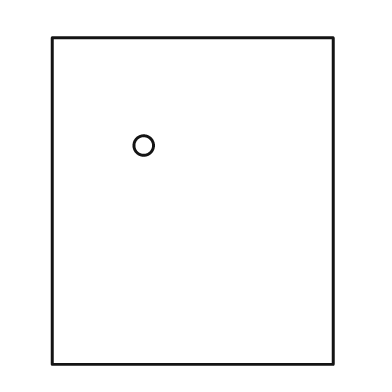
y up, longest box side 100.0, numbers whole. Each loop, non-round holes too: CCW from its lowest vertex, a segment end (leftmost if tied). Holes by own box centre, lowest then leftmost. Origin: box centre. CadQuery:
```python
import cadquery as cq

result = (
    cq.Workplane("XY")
    .moveTo(-43.0, -50.0)
    .lineTo(43.0, -50.0)
    .lineTo(43.0, 50.0)
    .lineTo(-43.0, 50.0)
    .close()
    .moveTo(-15.0, 17.0)
    .circle(3.0)
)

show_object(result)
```